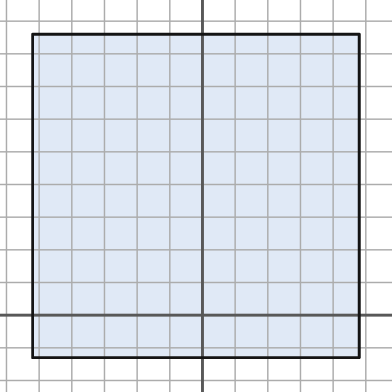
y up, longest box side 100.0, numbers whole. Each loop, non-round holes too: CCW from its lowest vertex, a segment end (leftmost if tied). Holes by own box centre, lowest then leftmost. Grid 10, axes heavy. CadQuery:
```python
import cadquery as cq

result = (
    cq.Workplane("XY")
    .moveTo(-52.0, -13.0)
    .lineTo(48.0, -13.0)
    .lineTo(48.0, 86.0)
    .lineTo(-52.0, 86.0)
    .close()
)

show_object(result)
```